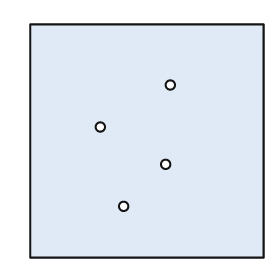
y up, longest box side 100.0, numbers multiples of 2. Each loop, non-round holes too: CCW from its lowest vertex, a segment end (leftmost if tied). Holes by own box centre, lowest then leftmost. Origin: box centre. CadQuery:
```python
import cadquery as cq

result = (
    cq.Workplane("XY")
    .moveTo(-50.0, -50.0)
    .lineTo(50.0, -50.0)
    .lineTo(50.0, 50.0)
    .lineTo(-50.0, 50.0)
    .close()
    .moveTo(-10.0, -28.0)
    .circle(2.0)
    .moveTo(8.0, -10.0)
    .circle(2.0)
    .moveTo(-20.0, 6.0)
    .circle(2.0)
    .moveTo(10.0, 24.0)
    .circle(2.0)
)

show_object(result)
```